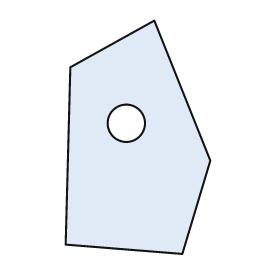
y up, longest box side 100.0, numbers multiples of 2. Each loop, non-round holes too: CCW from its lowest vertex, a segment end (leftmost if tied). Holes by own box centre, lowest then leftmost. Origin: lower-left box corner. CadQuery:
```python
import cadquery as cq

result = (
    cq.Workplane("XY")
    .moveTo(50.0, 0.0)
    .lineTo(62.0, 40.0)
    .lineTo(38.0, 100.0)
    .lineTo(2.0, 80.0)
    .lineTo(0.0, 4.0)
    .close()
    .moveTo(26.0, 56.0)
    .circle(8.0)
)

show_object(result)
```